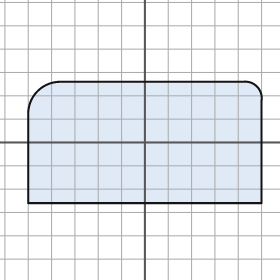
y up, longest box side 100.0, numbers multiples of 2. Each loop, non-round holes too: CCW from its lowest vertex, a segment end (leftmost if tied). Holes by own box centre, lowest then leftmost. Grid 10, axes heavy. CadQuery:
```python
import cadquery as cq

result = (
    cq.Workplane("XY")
    .moveTo(-50.0, -26.0)
    .lineTo(50.0, -26.0)
    .lineTo(50.0, 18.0)
    .threePointArc((48.0, 24.0), (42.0, 26.0))
    .lineTo(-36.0, 26.0)
    .threePointArc((-46.0, 22.0), (-50.0, 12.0))
    .close()
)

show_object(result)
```